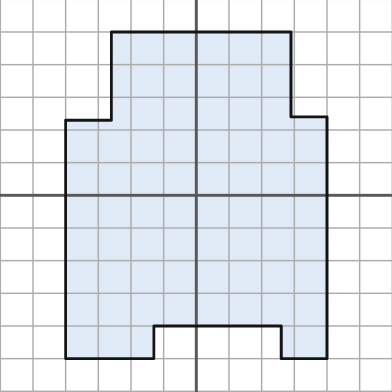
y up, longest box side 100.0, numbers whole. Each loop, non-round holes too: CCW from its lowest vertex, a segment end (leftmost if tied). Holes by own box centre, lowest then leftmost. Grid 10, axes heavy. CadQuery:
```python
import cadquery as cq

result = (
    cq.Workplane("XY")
    .moveTo(-40.0, -50.0)
    .lineTo(-13.0, -50.0)
    .lineTo(-13.0, -40.0)
    .lineTo(26.0, -40.0)
    .lineTo(26.0, -50.0)
    .lineTo(40.0, -50.0)
    .lineTo(40.0, 24.0)
    .lineTo(29.0, 24.0)
    .lineTo(29.0, 50.0)
    .lineTo(-26.0, 50.0)
    .lineTo(-26.0, 23.0)
    .lineTo(-40.0, 23.0)
    .close()
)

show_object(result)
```